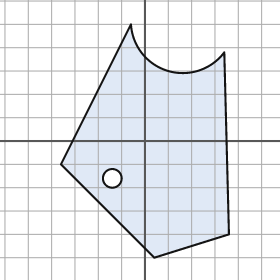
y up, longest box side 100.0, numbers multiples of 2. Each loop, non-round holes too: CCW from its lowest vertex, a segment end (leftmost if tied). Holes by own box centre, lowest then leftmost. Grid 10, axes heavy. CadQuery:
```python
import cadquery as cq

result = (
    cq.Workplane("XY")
    .moveTo(4.0, -50.0)
    .lineTo(36.0, -40.0)
    .lineTo(34.0, 38.0)
    .threePointArc((10.0, 30.0), (-6.0, 50.0))
    .lineTo(-36.0, -10.0)
    .close()
    .moveTo(-14.0, -16.0)
    .circle(4.0)
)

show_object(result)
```